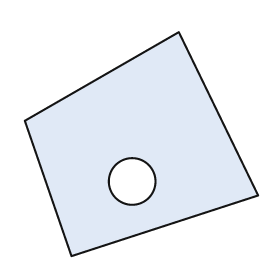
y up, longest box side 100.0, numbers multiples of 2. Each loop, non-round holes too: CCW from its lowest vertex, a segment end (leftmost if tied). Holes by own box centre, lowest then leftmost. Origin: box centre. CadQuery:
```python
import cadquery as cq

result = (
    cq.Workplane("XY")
    .moveTo(-30.0, -48.0)
    .lineTo(50.0, -22.0)
    .lineTo(16.0, 48.0)
    .lineTo(-50.0, 10.0)
    .close()
    .moveTo(-4.0, -16.0)
    .circle(10.0)
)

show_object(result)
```